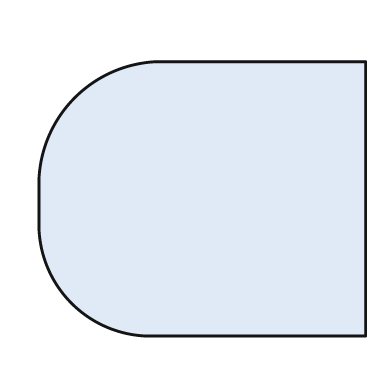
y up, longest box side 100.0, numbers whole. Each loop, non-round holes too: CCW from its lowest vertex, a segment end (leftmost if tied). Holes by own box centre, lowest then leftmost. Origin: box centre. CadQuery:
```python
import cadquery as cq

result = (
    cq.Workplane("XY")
    .moveTo(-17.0, -42.0)
    .lineTo(50.0, -42.0)
    .lineTo(50.0, 42.0)
    .lineTo(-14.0, 42.0)
    .threePointArc((-39.0, 31.0), (-50.0, 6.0))
    .lineTo(-50.0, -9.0)
    .threePointArc((-40.0, -32.0), (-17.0, -42.0))
    .close()
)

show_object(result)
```